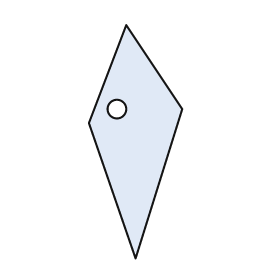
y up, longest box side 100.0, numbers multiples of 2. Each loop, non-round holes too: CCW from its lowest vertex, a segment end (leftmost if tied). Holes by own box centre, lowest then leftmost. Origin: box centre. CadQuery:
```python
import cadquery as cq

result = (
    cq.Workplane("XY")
    .moveTo(0.0, -50.0)
    .lineTo(20.0, 14.0)
    .lineTo(-4.0, 50.0)
    .lineTo(-20.0, 8.0)
    .close()
    .moveTo(-8.0, 14.0)
    .circle(4.0)
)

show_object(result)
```